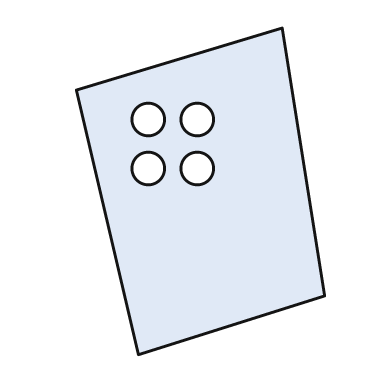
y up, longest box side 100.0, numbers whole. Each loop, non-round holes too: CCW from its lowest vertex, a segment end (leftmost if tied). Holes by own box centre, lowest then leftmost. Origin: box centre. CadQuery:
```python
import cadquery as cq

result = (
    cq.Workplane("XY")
    .moveTo(-19.0, -50.0)
    .lineTo(38.0, -32.0)
    .lineTo(25.0, 50.0)
    .lineTo(-38.0, 31.0)
    .close()
    .moveTo(-16.0, 7.0)
    .circle(5.0)
    .moveTo(-1.0, 7.0)
    .circle(5.0)
    .moveTo(-16.0, 22.0)
    .circle(5.0)
    .moveTo(-1.0, 22.0)
    .circle(5.0)
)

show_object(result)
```